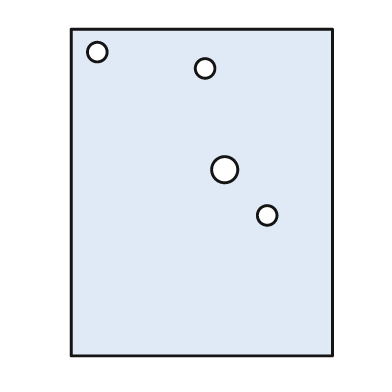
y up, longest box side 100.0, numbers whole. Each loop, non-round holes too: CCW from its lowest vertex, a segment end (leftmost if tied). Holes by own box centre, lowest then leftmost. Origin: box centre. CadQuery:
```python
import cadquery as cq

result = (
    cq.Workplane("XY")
    .moveTo(-40.0, -50.0)
    .lineTo(40.0, -50.0)
    .lineTo(40.0, 50.0)
    .lineTo(-40.0, 50.0)
    .close()
    .moveTo(20.0, -7.0)
    .circle(3.0)
    .moveTo(7.0, 7.0)
    .circle(4.0)
    .moveTo(1.0, 38.0)
    .circle(3.0)
    .moveTo(-32.0, 43.0)
    .circle(3.0)
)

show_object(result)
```